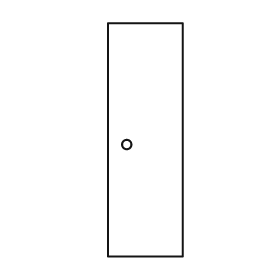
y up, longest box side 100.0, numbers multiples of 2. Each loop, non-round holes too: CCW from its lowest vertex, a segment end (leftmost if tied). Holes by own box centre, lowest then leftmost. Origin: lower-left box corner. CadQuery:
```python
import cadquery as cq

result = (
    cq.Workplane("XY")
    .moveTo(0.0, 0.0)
    .lineTo(32.0, 0.0)
    .lineTo(32.0, 100.0)
    .lineTo(0.0, 100.0)
    .close()
    .moveTo(8.0, 48.0)
    .circle(2.0)
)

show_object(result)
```